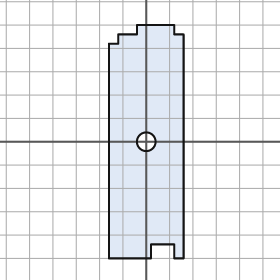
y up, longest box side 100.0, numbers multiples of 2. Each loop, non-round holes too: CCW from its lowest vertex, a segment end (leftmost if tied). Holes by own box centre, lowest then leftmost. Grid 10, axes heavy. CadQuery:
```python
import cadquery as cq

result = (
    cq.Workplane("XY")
    .moveTo(-16.0, -50.0)
    .lineTo(2.0, -50.0)
    .lineTo(2.0, -44.0)
    .lineTo(12.0, -44.0)
    .lineTo(12.0, -50.0)
    .lineTo(16.0, -50.0)
    .lineTo(16.0, 46.0)
    .lineTo(12.0, 46.0)
    .lineTo(12.0, 50.0)
    .lineTo(-4.0, 50.0)
    .lineTo(-4.0, 46.0)
    .lineTo(-12.0, 46.0)
    .lineTo(-12.0, 42.0)
    .lineTo(-16.0, 42.0)
    .close()
    .moveTo(0.0, 0.0)
    .circle(4.0)
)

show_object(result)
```